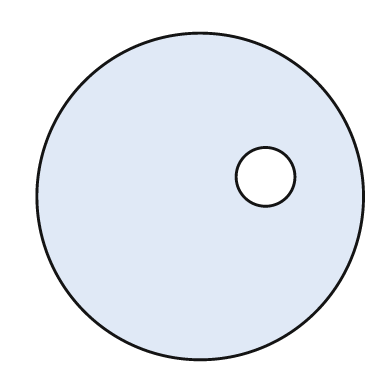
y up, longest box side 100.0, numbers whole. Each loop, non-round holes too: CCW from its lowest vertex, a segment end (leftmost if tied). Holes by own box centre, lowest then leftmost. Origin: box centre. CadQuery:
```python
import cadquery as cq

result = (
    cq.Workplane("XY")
    .moveTo(0.0, 0.0)
    .circle(50.0)
    .moveTo(20.0, 6.0)
    .circle(9.0)
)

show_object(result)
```